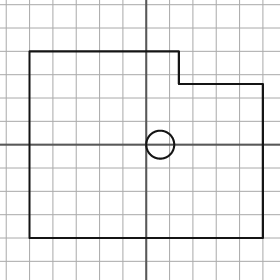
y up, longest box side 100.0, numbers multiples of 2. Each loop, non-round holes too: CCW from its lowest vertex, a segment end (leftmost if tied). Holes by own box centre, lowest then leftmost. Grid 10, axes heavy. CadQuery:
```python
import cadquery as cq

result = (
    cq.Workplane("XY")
    .moveTo(-50.0, -40.0)
    .lineTo(50.0, -40.0)
    .lineTo(50.0, 26.0)
    .lineTo(14.0, 26.0)
    .lineTo(14.0, 40.0)
    .lineTo(-50.0, 40.0)
    .close()
    .moveTo(6.0, 0.0)
    .circle(6.0)
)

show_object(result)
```